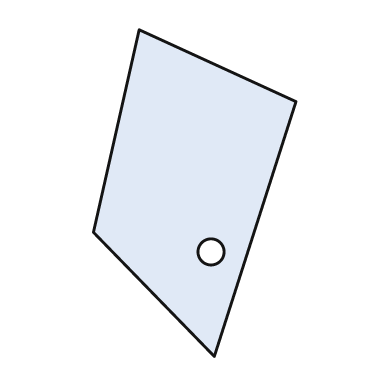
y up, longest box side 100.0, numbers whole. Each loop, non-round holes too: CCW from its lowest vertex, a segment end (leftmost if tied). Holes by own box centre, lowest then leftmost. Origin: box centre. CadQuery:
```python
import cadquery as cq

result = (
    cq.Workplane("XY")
    .moveTo(6.0, -50.0)
    .lineTo(31.0, 28.0)
    .lineTo(-17.0, 50.0)
    .lineTo(-31.0, -12.0)
    .close()
    .moveTo(5.0, -18.0)
    .circle(4.0)
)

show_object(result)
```